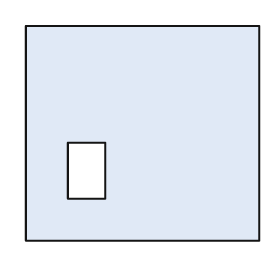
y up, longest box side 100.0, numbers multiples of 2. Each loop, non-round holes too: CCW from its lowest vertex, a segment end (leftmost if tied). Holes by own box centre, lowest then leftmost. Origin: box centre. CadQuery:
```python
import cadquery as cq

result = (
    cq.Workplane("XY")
    .moveTo(-50.0, -46.0)
    .lineTo(50.0, -46.0)
    .lineTo(50.0, 46.0)
    .lineTo(-50.0, 46.0)
    .close()
    .moveTo(-32.0, -28.0)
    .lineTo(-16.0, -28.0)
    .lineTo(-16.0, -4.0)
    .lineTo(-32.0, -4.0)
    .close()
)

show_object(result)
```